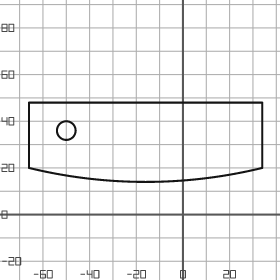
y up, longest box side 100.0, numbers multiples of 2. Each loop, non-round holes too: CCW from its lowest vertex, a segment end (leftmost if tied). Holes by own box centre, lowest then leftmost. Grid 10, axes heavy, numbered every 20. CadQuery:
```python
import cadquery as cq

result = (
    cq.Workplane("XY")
    .moveTo(-66.0, 20.0)
    .threePointArc((-16.0, 14.0), (34.0, 20.0))
    .lineTo(34.0, 48.0)
    .lineTo(-66.0, 48.0)
    .close()
    .moveTo(-50.0, 36.0)
    .circle(4.0)
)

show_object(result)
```